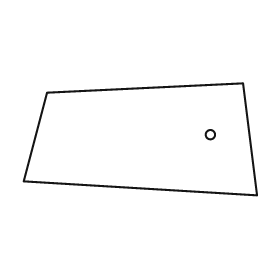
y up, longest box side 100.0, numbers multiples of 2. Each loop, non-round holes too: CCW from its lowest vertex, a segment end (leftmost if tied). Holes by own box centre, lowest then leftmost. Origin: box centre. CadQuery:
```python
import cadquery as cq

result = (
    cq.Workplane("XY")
    .moveTo(50.0, -24.0)
    .lineTo(44.0, 24.0)
    .lineTo(-40.0, 20.0)
    .lineTo(-50.0, -18.0)
    .close()
    .moveTo(30.0, 2.0)
    .circle(2.0)
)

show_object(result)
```